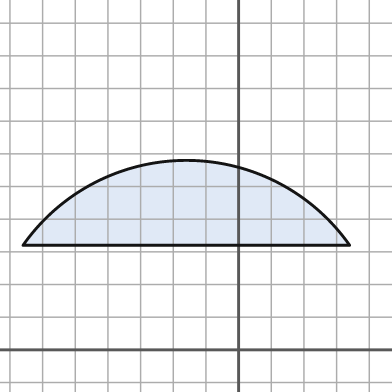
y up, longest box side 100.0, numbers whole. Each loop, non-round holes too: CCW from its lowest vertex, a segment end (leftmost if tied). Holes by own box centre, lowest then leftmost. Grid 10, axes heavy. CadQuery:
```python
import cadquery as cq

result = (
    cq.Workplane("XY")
    .moveTo(-66.0, 32.0)
    .lineTo(34.0, 32.0)
    .threePointArc((-16.0, 58.0), (-66.0, 32.0))
    .close()
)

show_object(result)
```